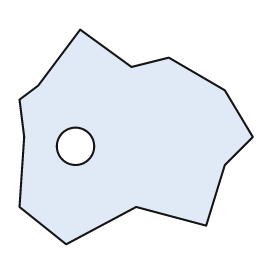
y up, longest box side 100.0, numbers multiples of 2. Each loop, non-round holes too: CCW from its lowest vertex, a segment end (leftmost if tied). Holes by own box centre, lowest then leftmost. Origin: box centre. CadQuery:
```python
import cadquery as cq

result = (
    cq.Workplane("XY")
    .moveTo(-30.0, -46.0)
    .lineTo(0.0, -30.0)
    .lineTo(30.0, -38.0)
    .lineTo(38.0, -12.0)
    .lineTo(50.0, 0.0)
    .lineTo(38.0, 20.0)
    .lineTo(14.0, 34.0)
    .lineTo(-2.0, 30.0)
    .lineTo(-24.0, 46.0)
    .lineTo(-42.0, 22.0)
    .lineTo(-50.0, 16.0)
    .lineTo(-48.0, 0.0)
    .lineTo(-50.0, -30.0)
    .close()
    .moveTo(-26.0, -4.0)
    .circle(8.0)
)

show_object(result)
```